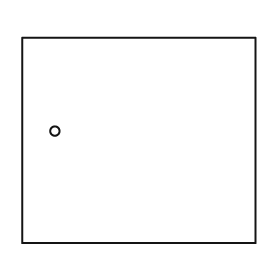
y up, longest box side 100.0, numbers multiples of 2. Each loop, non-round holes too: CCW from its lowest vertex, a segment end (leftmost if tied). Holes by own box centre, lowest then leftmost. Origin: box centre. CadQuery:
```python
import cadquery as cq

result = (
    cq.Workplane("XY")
    .moveTo(-50.0, -44.0)
    .lineTo(50.0, -44.0)
    .lineTo(50.0, 44.0)
    .lineTo(-50.0, 44.0)
    .close()
    .moveTo(-36.0, 4.0)
    .circle(2.0)
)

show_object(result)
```